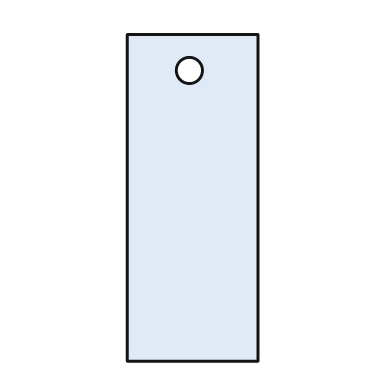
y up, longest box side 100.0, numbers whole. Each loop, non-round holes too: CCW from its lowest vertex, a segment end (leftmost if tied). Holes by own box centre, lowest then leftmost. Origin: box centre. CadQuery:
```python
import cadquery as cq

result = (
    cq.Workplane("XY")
    .moveTo(-20.0, -50.0)
    .lineTo(20.0, -50.0)
    .lineTo(20.0, 50.0)
    .lineTo(-20.0, 50.0)
    .close()
    .moveTo(-1.0, 39.0)
    .circle(4.0)
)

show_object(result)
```